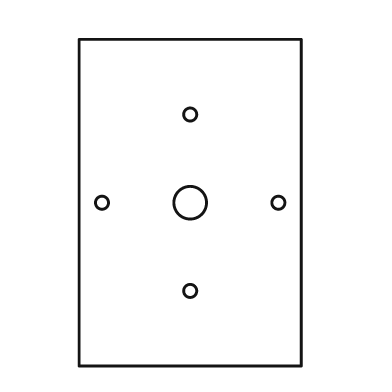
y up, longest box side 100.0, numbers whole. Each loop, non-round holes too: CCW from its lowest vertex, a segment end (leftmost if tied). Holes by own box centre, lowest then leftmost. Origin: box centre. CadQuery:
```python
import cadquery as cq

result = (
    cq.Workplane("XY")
    .moveTo(-34.0, -50.0)
    .lineTo(34.0, -50.0)
    .lineTo(34.0, 50.0)
    .lineTo(-34.0, 50.0)
    .close()
    .moveTo(0.0, -27.0)
    .circle(2.0)
    .moveTo(-27.0, 0.0)
    .circle(2.0)
    .moveTo(0.0, 0.0)
    .circle(5.0)
    .moveTo(27.0, 0.0)
    .circle(2.0)
    .moveTo(0.0, 27.0)
    .circle(2.0)
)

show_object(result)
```